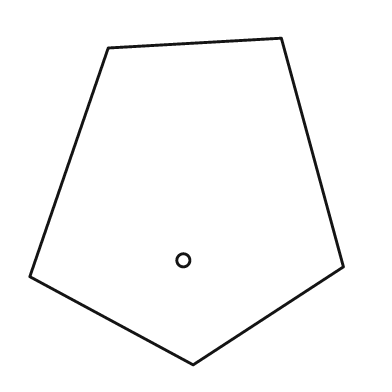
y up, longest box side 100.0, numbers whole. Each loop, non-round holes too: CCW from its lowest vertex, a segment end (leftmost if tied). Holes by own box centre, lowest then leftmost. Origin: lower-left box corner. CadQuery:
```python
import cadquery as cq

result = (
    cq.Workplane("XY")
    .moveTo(50.0, 0.0)
    .lineTo(96.0, 30.0)
    .lineTo(77.0, 100.0)
    .lineTo(24.0, 97.0)
    .lineTo(0.0, 27.0)
    .close()
    .moveTo(47.0, 32.0)
    .circle(2.0)
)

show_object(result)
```